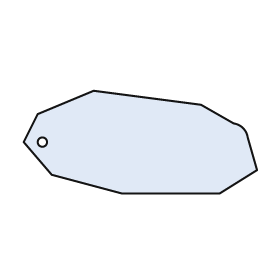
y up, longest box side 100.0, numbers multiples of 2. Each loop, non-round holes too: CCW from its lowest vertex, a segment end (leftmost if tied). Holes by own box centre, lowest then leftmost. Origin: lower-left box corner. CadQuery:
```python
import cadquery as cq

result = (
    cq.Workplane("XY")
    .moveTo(42.0, 0.0)
    .lineTo(84.0, 0.0)
    .lineTo(100.0, 10.0)
    .lineTo(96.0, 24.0)
    .threePointArc((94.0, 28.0), (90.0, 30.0))
    .lineTo(76.0, 38.0)
    .lineTo(30.0, 44.0)
    .lineTo(6.0, 34.0)
    .lineTo(0.0, 22.0)
    .lineTo(12.0, 8.0)
    .close()
    .moveTo(8.0, 22.0)
    .circle(2.0)
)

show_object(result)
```